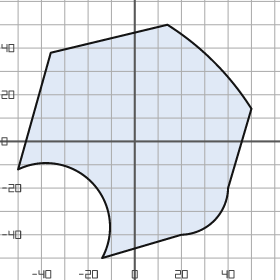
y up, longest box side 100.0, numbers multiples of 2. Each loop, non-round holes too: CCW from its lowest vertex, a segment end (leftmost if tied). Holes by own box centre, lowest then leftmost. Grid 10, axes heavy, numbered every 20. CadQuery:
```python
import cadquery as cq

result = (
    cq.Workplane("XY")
    .moveTo(-14.0, -50.0)
    .lineTo(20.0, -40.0)
    .threePointArc((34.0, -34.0), (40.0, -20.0))
    .lineTo(50.0, 14.0)
    .threePointArc((34.0, 34.0), (14.0, 50.0))
    .lineTo(-36.0, 38.0)
    .lineTo(-50.0, -12.0)
    .threePointArc((-18.0, -18.0), (-14.0, -50.0))
    .close()
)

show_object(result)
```